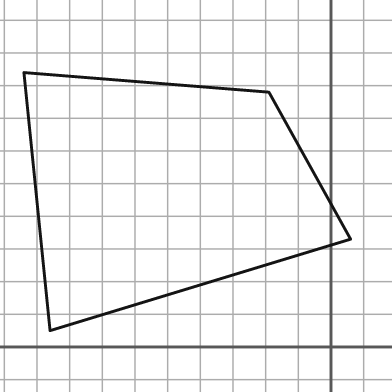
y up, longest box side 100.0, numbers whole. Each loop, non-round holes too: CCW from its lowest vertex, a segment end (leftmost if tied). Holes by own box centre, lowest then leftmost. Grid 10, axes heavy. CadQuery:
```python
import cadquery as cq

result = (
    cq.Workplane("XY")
    .moveTo(-86.0, 5.0)
    .lineTo(6.0, 33.0)
    .lineTo(-19.0, 78.0)
    .lineTo(-94.0, 84.0)
    .close()
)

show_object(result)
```